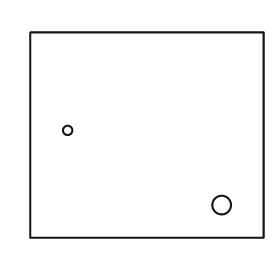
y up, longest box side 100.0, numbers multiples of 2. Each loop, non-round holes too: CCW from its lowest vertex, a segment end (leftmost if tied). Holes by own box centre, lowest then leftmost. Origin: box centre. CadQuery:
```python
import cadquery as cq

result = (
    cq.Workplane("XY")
    .moveTo(-50.0, -44.0)
    .lineTo(50.0, -44.0)
    .lineTo(50.0, 44.0)
    .lineTo(-50.0, 44.0)
    .close()
    .moveTo(32.0, -30.0)
    .circle(4.0)
    .moveTo(-34.0, 2.0)
    .circle(2.0)
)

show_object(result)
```